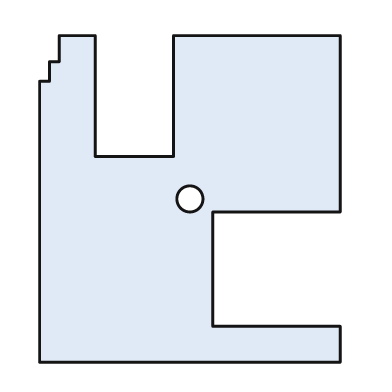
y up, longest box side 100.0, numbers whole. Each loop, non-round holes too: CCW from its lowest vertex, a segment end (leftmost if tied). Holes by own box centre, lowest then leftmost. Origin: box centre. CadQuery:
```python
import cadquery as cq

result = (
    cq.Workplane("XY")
    .moveTo(-46.0, -50.0)
    .lineTo(46.0, -50.0)
    .lineTo(46.0, -39.0)
    .lineTo(7.0, -39.0)
    .lineTo(7.0, -4.0)
    .lineTo(46.0, -4.0)
    .lineTo(46.0, 50.0)
    .lineTo(-5.0, 50.0)
    .lineTo(-5.0, 13.0)
    .lineTo(-29.0, 13.0)
    .lineTo(-29.0, 50.0)
    .lineTo(-40.0, 50.0)
    .lineTo(-40.0, 42.0)
    .lineTo(-43.0, 42.0)
    .lineTo(-43.0, 36.0)
    .lineTo(-46.0, 36.0)
    .close()
    .moveTo(0.0, 0.0)
    .circle(4.0)
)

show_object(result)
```